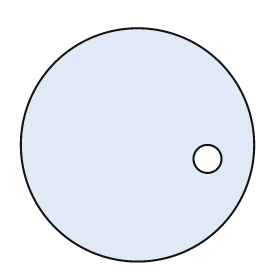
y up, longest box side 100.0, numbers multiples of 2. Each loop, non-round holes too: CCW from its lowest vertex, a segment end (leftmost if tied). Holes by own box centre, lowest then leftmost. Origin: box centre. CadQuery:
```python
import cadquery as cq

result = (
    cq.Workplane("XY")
    .moveTo(0.0, 0.0)
    .circle(50.0)
    .moveTo(30.0, -6.0)
    .circle(6.0)
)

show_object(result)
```